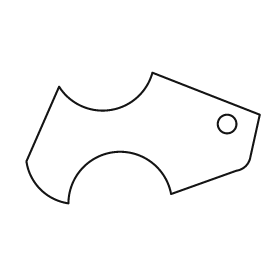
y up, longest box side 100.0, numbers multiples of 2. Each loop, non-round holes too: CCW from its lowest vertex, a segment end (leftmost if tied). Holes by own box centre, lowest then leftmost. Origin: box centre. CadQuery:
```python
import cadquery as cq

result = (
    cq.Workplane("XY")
    .moveTo(-32.0, -28.0)
    .threePointArc((-12.0, -6.0), (12.0, -24.0))
    .lineTo(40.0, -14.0)
    .threePointArc((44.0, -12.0), (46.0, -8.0))
    .lineTo(50.0, 10.0)
    .lineTo(4.0, 28.0)
    .threePointArc((-14.0, 12.0), (-36.0, 22.0))
    .lineTo(-50.0, -10.0)
    .threePointArc((-44.0, -22.0), (-32.0, -28.0))
    .close()
    .moveTo(36.0, 6.0)
    .circle(4.0)
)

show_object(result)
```